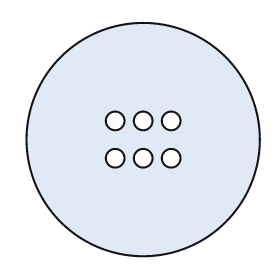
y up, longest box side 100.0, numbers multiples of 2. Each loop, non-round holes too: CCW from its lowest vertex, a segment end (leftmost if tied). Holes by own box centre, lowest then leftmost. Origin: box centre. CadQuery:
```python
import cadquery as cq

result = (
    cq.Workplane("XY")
    .moveTo(0.0, 0.0)
    .circle(50.0)
    .moveTo(-12.0, -8.0)
    .circle(4.0)
    .moveTo(0.0, -8.0)
    .circle(4.0)
    .moveTo(12.0, -8.0)
    .circle(4.0)
    .moveTo(-12.0, 8.0)
    .circle(4.0)
    .moveTo(0.0, 8.0)
    .circle(4.0)
    .moveTo(12.0, 8.0)
    .circle(4.0)
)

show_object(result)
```